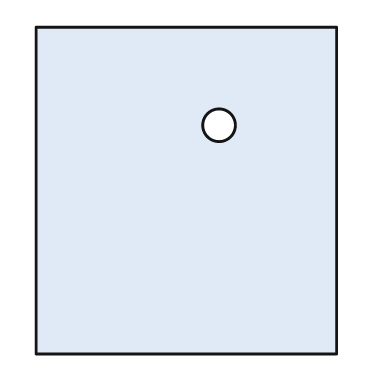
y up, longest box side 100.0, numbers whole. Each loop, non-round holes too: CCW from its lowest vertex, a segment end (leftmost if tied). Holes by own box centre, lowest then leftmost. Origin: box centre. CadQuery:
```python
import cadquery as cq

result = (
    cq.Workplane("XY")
    .moveTo(-46.0, -50.0)
    .lineTo(46.0, -50.0)
    .lineTo(46.0, 50.0)
    .lineTo(-46.0, 50.0)
    .close()
    .moveTo(10.0, 20.0)
    .circle(5.0)
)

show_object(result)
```